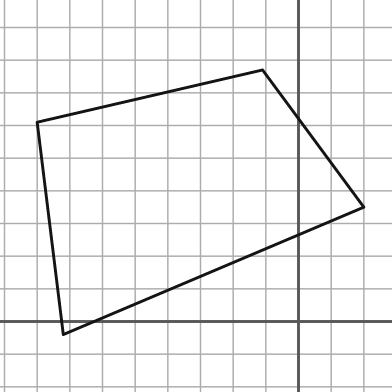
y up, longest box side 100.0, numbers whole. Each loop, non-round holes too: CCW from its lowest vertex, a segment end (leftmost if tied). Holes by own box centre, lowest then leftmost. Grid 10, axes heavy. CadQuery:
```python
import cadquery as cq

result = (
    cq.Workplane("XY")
    .moveTo(-72.0, -4.0)
    .lineTo(20.0, 35.0)
    .lineTo(-11.0, 77.0)
    .lineTo(-80.0, 61.0)
    .close()
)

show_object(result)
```